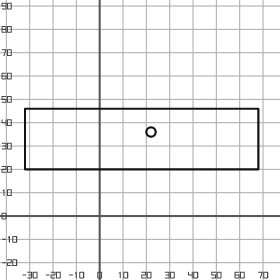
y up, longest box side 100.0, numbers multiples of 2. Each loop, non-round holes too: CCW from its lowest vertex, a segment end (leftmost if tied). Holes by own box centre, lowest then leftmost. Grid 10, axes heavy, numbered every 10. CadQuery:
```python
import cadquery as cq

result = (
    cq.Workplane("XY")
    .moveTo(-32.0, 20.0)
    .lineTo(68.0, 20.0)
    .lineTo(68.0, 46.0)
    .lineTo(-32.0, 46.0)
    .close()
    .moveTo(22.0, 36.0)
    .circle(2.0)
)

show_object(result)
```